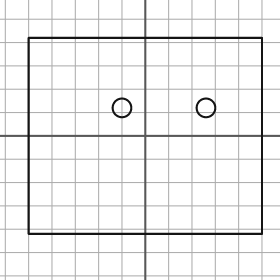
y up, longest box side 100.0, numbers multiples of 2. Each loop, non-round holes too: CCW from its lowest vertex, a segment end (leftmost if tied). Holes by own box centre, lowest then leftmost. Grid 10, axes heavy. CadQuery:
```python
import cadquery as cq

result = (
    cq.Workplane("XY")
    .moveTo(-50.0, -42.0)
    .lineTo(50.0, -42.0)
    .lineTo(50.0, 42.0)
    .lineTo(-50.0, 42.0)
    .close()
    .moveTo(-10.0, 12.0)
    .circle(4.0)
    .moveTo(26.0, 12.0)
    .circle(4.0)
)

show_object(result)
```